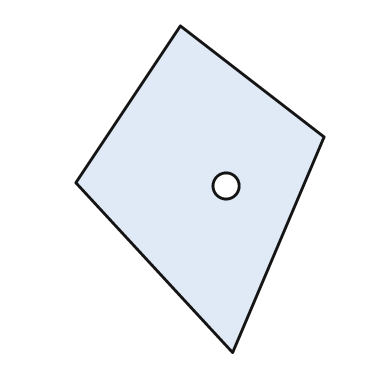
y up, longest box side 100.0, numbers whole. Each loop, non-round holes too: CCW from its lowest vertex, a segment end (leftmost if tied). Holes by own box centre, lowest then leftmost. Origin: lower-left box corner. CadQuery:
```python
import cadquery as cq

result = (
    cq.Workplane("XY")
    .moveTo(48.0, 0.0)
    .lineTo(76.0, 66.0)
    .lineTo(32.0, 100.0)
    .lineTo(0.0, 52.0)
    .close()
    .moveTo(46.0, 51.0)
    .circle(4.0)
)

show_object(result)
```